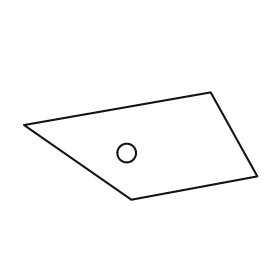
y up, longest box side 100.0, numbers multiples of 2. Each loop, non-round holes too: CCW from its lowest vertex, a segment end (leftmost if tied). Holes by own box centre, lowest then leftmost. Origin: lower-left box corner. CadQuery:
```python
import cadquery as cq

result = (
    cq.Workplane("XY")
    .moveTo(46.0, 0.0)
    .lineTo(100.0, 10.0)
    .lineTo(80.0, 46.0)
    .lineTo(0.0, 32.0)
    .close()
    .moveTo(44.0, 20.0)
    .circle(4.0)
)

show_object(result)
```